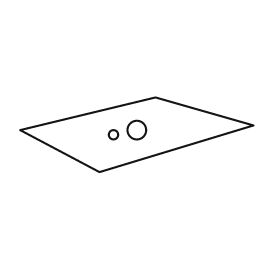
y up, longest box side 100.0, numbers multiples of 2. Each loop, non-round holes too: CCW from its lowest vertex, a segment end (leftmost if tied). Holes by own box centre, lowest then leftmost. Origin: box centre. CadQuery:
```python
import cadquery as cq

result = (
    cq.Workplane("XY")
    .moveTo(-16.0, -16.0)
    .lineTo(50.0, 4.0)
    .lineTo(8.0, 16.0)
    .lineTo(-50.0, 2.0)
    .close()
    .moveTo(-10.0, 0.0)
    .circle(2.0)
    .moveTo(0.0, 2.0)
    .circle(4.0)
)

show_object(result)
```